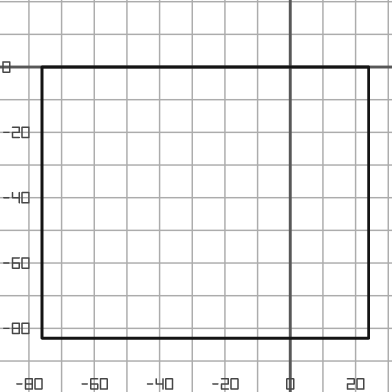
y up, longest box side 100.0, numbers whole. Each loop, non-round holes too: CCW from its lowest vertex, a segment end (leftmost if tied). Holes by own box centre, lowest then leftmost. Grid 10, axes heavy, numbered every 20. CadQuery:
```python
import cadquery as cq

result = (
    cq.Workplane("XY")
    .moveTo(-76.0, -83.0)
    .lineTo(24.0, -83.0)
    .lineTo(24.0, 0.0)
    .lineTo(-76.0, 0.0)
    .close()
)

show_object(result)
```